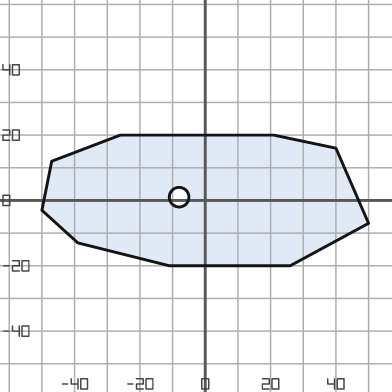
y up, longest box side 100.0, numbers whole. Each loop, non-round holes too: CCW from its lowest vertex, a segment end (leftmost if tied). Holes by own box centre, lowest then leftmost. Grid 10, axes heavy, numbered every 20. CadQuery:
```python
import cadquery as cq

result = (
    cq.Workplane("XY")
    .moveTo(-11.0, -20.0)
    .lineTo(26.0, -20.0)
    .lineTo(50.0, -7.0)
    .lineTo(40.0, 16.0)
    .lineTo(21.0, 20.0)
    .lineTo(-26.0, 20.0)
    .lineTo(-47.0, 12.0)
    .lineTo(-50.0, -3.0)
    .lineTo(-39.0, -13.0)
    .close()
    .moveTo(-8.0, 1.0)
    .circle(3.0)
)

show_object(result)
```